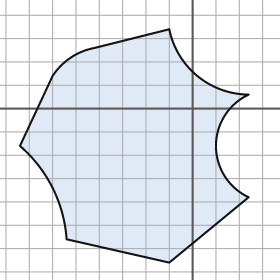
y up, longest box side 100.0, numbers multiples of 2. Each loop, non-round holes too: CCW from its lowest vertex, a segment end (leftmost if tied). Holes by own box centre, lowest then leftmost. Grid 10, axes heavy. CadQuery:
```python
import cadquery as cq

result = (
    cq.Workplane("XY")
    .moveTo(-10.0, -66.0)
    .lineTo(24.0, -38.0)
    .threePointArc((10.0, -16.0), (24.0, 6.0))
    .threePointArc((2.0, 14.0), (-10.0, 34.0))
    .lineTo(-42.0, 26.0)
    .threePointArc((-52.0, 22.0), (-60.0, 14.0))
    .lineTo(-74.0, -16.0)
    .threePointArc((-60.0, -34.0), (-54.0, -56.0))
    .close()
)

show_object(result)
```